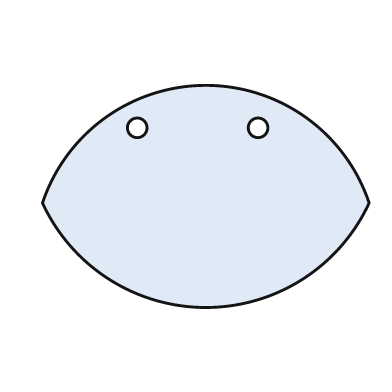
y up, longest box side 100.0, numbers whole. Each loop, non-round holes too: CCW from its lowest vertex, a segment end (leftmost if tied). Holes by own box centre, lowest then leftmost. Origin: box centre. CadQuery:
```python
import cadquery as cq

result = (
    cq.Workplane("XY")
    .moveTo(-50.0, -2.0)
    .threePointArc((0.0, -34.0), (50.0, -2.0))
    .threePointArc((0.0, 34.0), (-50.0, -2.0))
    .close()
    .moveTo(-21.0, 21.0)
    .circle(3.0)
    .moveTo(16.0, 21.0)
    .circle(3.0)
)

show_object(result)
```